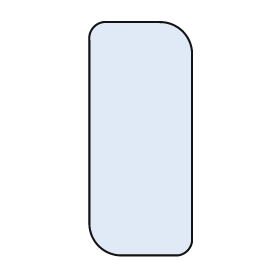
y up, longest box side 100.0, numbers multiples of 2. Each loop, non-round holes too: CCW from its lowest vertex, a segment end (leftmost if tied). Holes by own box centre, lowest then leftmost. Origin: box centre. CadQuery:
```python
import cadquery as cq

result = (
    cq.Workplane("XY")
    .moveTo(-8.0, -50.0)
    .lineTo(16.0, -50.0)
    .threePointArc((20.0, -48.0), (22.0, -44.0))
    .lineTo(22.0, 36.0)
    .threePointArc((18.0, 46.0), (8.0, 50.0))
    .lineTo(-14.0, 50.0)
    .threePointArc((-20.0, 48.0), (-22.0, 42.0))
    .lineTo(-22.0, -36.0)
    .threePointArc((-18.0, -46.0), (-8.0, -50.0))
    .close()
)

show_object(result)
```